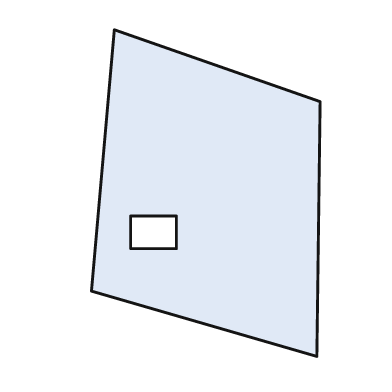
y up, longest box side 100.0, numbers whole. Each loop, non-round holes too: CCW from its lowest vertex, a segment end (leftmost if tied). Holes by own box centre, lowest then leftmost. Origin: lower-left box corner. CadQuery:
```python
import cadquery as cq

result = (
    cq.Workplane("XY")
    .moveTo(69.0, 0.0)
    .lineTo(70.0, 78.0)
    .lineTo(7.0, 100.0)
    .lineTo(0.0, 20.0)
    .close()
    .moveTo(12.0, 33.0)
    .lineTo(26.0, 33.0)
    .lineTo(26.0, 43.0)
    .lineTo(12.0, 43.0)
    .close()
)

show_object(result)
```